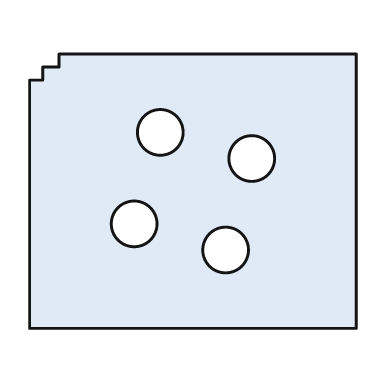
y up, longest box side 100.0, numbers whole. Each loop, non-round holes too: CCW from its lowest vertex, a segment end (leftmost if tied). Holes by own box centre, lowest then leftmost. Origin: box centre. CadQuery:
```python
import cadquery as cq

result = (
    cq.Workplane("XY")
    .moveTo(-50.0, -42.0)
    .lineTo(50.0, -42.0)
    .lineTo(50.0, 42.0)
    .lineTo(-41.0, 42.0)
    .lineTo(-41.0, 38.0)
    .lineTo(-46.0, 38.0)
    .lineTo(-46.0, 34.0)
    .lineTo(-50.0, 34.0)
    .close()
    .moveTo(10.0, -18.0)
    .circle(7.0)
    .moveTo(-18.0, -10.0)
    .circle(7.0)
    .moveTo(18.0, 10.0)
    .circle(7.0)
    .moveTo(-10.0, 18.0)
    .circle(7.0)
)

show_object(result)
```